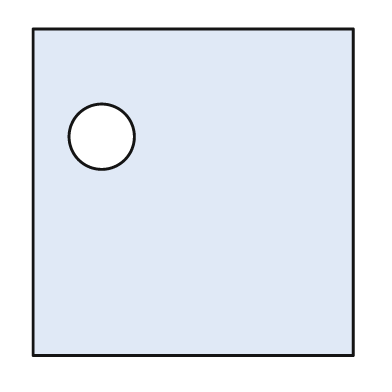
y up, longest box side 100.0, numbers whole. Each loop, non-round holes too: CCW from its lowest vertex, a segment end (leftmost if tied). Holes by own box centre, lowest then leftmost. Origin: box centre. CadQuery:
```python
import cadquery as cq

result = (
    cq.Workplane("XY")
    .moveTo(-49.0, -50.0)
    .lineTo(49.0, -50.0)
    .lineTo(49.0, 50.0)
    .lineTo(-49.0, 50.0)
    .close()
    .moveTo(-28.0, 17.0)
    .circle(10.0)
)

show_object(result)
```